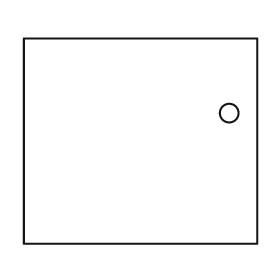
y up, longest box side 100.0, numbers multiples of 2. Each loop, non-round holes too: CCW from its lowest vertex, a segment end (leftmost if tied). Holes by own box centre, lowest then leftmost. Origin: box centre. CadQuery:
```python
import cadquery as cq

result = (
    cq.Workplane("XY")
    .moveTo(-50.0, -44.0)
    .lineTo(50.0, -44.0)
    .lineTo(50.0, 44.0)
    .lineTo(-50.0, 44.0)
    .close()
    .moveTo(38.0, 12.0)
    .circle(4.0)
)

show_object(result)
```